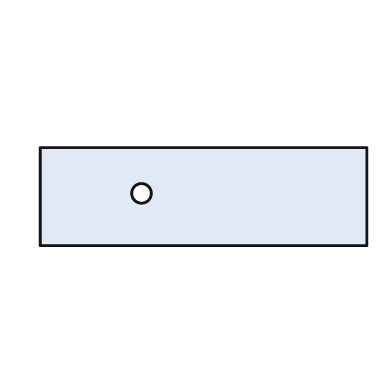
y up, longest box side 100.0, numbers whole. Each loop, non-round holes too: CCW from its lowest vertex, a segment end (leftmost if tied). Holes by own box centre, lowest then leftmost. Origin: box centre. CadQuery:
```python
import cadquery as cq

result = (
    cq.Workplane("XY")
    .moveTo(-50.0, -15.0)
    .lineTo(50.0, -15.0)
    .lineTo(50.0, 15.0)
    .lineTo(-50.0, 15.0)
    .close()
    .moveTo(-19.0, 1.0)
    .circle(3.0)
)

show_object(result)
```